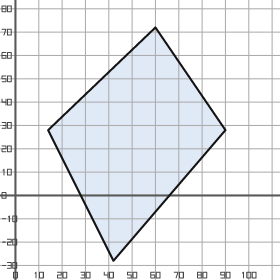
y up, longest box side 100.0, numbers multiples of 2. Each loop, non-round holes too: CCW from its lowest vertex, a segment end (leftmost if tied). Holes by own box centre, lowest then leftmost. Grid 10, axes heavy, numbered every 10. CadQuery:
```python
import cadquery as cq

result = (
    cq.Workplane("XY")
    .moveTo(42.0, -28.0)
    .lineTo(90.0, 28.0)
    .lineTo(60.0, 72.0)
    .lineTo(14.0, 28.0)
    .close()
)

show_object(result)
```